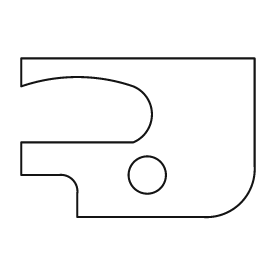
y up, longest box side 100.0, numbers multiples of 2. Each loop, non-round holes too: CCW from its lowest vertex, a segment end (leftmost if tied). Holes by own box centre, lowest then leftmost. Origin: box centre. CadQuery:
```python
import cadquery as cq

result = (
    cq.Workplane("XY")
    .moveTo(-26.0, -34.0)
    .lineTo(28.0, -34.0)
    .threePointArc((44.0, -28.0), (50.0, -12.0))
    .lineTo(50.0, 34.0)
    .lineTo(-50.0, 34.0)
    .lineTo(-50.0, 22.0)
    .threePointArc((-26.0, 26.0), (-2.0, 22.0))
    .threePointArc((6.0, 10.0), (-2.0, -2.0))
    .lineTo(-50.0, -2.0)
    .lineTo(-50.0, -16.0)
    .lineTo(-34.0, -16.0)
    .threePointArc((-28.0, -18.0), (-26.0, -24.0))
    .close()
    .moveTo(4.0, -16.0)
    .circle(8.0)
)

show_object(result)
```